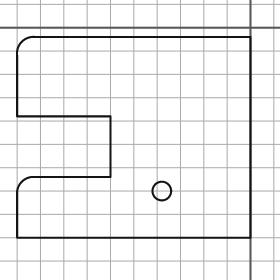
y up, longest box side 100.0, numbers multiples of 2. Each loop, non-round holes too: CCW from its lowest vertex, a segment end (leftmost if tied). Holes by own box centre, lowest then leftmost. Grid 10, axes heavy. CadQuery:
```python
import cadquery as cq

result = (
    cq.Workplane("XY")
    .moveTo(-100.0, -90.0)
    .lineTo(0.0, -90.0)
    .lineTo(0.0, -4.0)
    .lineTo(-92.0, -4.0)
    .threePointArc((-98.0, -6.0), (-100.0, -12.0))
    .lineTo(-100.0, -38.0)
    .lineTo(-60.0, -38.0)
    .lineTo(-60.0, -64.0)
    .lineTo(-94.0, -64.0)
    .threePointArc((-98.0, -66.0), (-100.0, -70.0))
    .close()
    .moveTo(-38.0, -70.0)
    .circle(4.0)
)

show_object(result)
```